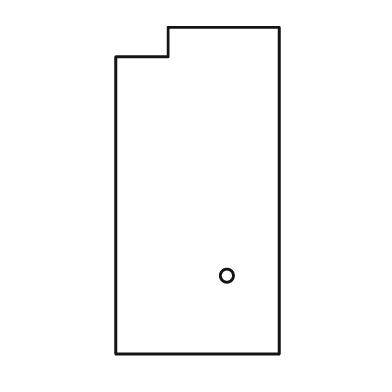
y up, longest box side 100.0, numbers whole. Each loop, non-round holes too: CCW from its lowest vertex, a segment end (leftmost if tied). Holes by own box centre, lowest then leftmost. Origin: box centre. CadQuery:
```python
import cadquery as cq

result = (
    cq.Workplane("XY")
    .moveTo(-25.0, -50.0)
    .lineTo(25.0, -50.0)
    .lineTo(25.0, 50.0)
    .lineTo(-9.0, 50.0)
    .lineTo(-9.0, 41.0)
    .lineTo(-25.0, 41.0)
    .close()
    .moveTo(9.0, -26.0)
    .circle(2.0)
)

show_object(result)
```